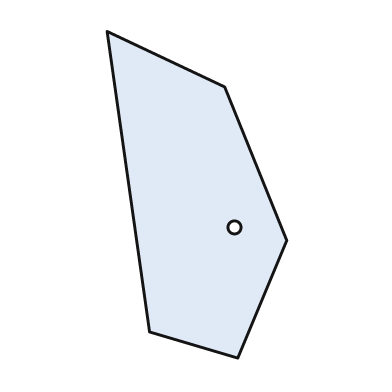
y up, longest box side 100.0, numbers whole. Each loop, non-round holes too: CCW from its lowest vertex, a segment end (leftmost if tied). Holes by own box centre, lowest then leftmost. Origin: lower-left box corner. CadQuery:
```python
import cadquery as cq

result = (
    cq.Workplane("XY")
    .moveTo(40.0, 0.0)
    .lineTo(55.0, 36.0)
    .lineTo(36.0, 83.0)
    .lineTo(0.0, 100.0)
    .lineTo(13.0, 8.0)
    .close()
    .moveTo(39.0, 40.0)
    .circle(2.0)
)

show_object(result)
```